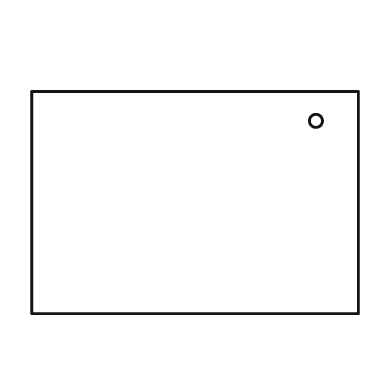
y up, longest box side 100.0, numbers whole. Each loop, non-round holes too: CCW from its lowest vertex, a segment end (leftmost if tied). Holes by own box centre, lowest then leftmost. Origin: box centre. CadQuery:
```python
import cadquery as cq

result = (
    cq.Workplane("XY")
    .moveTo(-50.0, -34.0)
    .lineTo(50.0, -34.0)
    .lineTo(50.0, 34.0)
    .lineTo(-50.0, 34.0)
    .close()
    .moveTo(37.0, 25.0)
    .circle(2.0)
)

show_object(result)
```